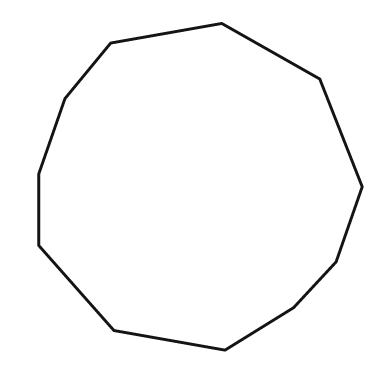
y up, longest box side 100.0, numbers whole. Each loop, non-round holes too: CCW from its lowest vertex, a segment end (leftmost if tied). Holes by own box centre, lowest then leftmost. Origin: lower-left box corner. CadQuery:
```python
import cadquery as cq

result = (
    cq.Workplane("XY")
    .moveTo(57.0, 0.0)
    .lineTo(78.0, 13.0)
    .lineTo(91.0, 27.0)
    .lineTo(99.0, 50.0)
    .lineTo(86.0, 83.0)
    .lineTo(56.0, 100.0)
    .lineTo(22.0, 94.0)
    .lineTo(8.0, 77.0)
    .lineTo(0.0, 54.0)
    .lineTo(0.0, 32.0)
    .lineTo(23.0, 6.0)
    .close()
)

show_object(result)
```